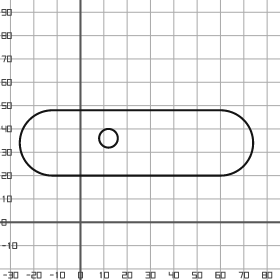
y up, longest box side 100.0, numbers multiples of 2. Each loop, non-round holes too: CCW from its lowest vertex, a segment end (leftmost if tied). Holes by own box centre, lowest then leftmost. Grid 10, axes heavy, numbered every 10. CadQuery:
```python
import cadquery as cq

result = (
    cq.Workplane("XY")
    .moveTo(-12.0, 20.0)
    .lineTo(60.0, 20.0)
    .threePointArc((74.0, 34.0), (60.0, 48.0))
    .lineTo(-12.0, 48.0)
    .threePointArc((-26.0, 34.0), (-12.0, 20.0))
    .close()
    .moveTo(12.0, 36.0)
    .circle(4.0)
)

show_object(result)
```